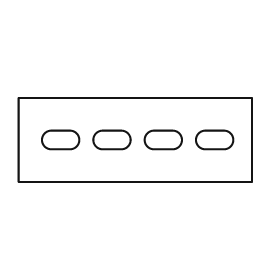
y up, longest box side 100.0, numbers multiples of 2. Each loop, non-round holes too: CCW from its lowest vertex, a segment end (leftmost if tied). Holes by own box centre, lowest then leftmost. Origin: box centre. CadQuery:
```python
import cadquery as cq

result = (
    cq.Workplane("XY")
    .moveTo(-50.0, -18.0)
    .lineTo(50.0, -18.0)
    .lineTo(50.0, 18.0)
    .lineTo(-50.0, 18.0)
    .close()
    .moveTo(-36.0, -4.0)
    .lineTo(-28.0, -4.0)
    .threePointArc((-24.0, 0.0), (-28.0, 4.0))
    .lineTo(-36.0, 4.0)
    .threePointArc((-40.0, 0.0), (-36.0, -4.0))
    .close()
    .moveTo(-14.0, -4.0)
    .lineTo(-6.0, -4.0)
    .threePointArc((-2.0, 0.0), (-6.0, 4.0))
    .lineTo(-14.0, 4.0)
    .threePointArc((-18.0, 0.0), (-14.0, -4.0))
    .close()
    .moveTo(8.0, -4.0)
    .lineTo(16.0, -4.0)
    .threePointArc((20.0, 0.0), (16.0, 4.0))
    .lineTo(8.0, 4.0)
    .threePointArc((4.0, 0.0), (8.0, -4.0))
    .close()
    .moveTo(30.0, -4.0)
    .lineTo(38.0, -4.0)
    .threePointArc((42.0, 0.0), (38.0, 4.0))
    .lineTo(30.0, 4.0)
    .threePointArc((26.0, 0.0), (30.0, -4.0))
    .close()
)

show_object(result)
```